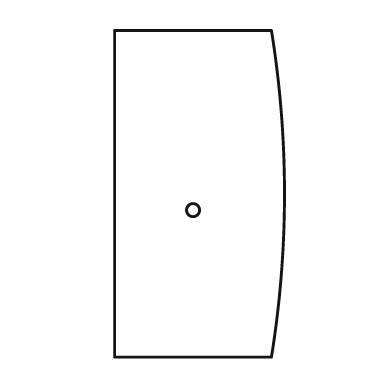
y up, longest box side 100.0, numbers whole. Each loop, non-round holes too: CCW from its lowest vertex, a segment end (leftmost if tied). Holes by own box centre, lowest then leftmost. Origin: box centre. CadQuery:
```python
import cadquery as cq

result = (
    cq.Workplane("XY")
    .moveTo(-26.0, -50.0)
    .lineTo(22.0, -50.0)
    .threePointArc((26.0, 0.0), (22.0, 50.0))
    .lineTo(-26.0, 50.0)
    .close()
    .moveTo(-2.0, -5.0)
    .circle(2.0)
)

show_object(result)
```